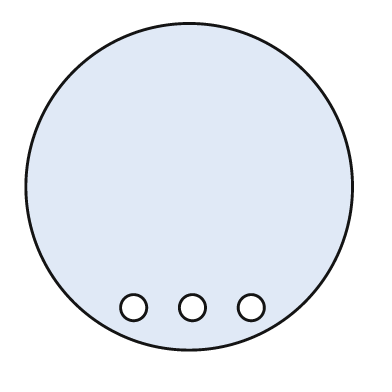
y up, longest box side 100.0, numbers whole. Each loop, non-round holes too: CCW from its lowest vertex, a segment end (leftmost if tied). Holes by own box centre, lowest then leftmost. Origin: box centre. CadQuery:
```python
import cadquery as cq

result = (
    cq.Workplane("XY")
    .moveTo(0.0, 0.0)
    .circle(50.0)
    .moveTo(-17.0, -37.0)
    .circle(4.0)
    .moveTo(1.0, -37.0)
    .circle(4.0)
    .moveTo(19.0, -37.0)
    .circle(4.0)
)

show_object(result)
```